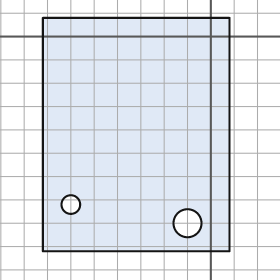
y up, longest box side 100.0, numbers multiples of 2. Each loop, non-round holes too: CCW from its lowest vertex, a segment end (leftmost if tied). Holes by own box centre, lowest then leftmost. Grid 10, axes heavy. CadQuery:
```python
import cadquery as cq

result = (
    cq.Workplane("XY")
    .moveTo(-72.0, -92.0)
    .lineTo(8.0, -92.0)
    .lineTo(8.0, 8.0)
    .lineTo(-72.0, 8.0)
    .close()
    .moveTo(-10.0, -80.0)
    .circle(6.0)
    .moveTo(-60.0, -72.0)
    .circle(4.0)
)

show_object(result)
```